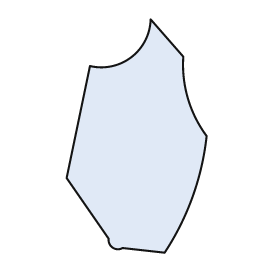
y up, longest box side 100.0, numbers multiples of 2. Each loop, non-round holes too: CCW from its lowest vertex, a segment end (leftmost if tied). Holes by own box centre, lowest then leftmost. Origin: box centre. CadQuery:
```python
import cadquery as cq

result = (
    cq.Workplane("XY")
    .moveTo(12.0, -50.0)
    .threePointArc((24.0, -26.0), (30.0, 0.0))
    .threePointArc((22.0, 16.0), (20.0, 34.0))
    .lineTo(6.0, 50.0)
    .threePointArc((-2.0, 34.0), (-20.0, 30.0))
    .lineTo(-30.0, -18.0)
    .lineTo(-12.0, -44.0)
    .threePointArc((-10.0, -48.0), (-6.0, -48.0))
    .close()
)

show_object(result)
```